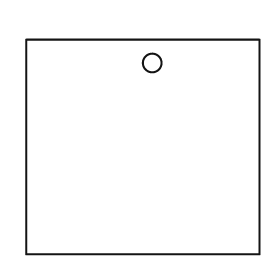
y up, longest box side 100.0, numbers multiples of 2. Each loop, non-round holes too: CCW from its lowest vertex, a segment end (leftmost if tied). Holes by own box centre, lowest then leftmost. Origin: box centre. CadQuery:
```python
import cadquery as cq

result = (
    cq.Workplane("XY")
    .moveTo(-50.0, -46.0)
    .lineTo(50.0, -46.0)
    .lineTo(50.0, 46.0)
    .lineTo(-50.0, 46.0)
    .close()
    .moveTo(4.0, 36.0)
    .circle(4.0)
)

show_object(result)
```